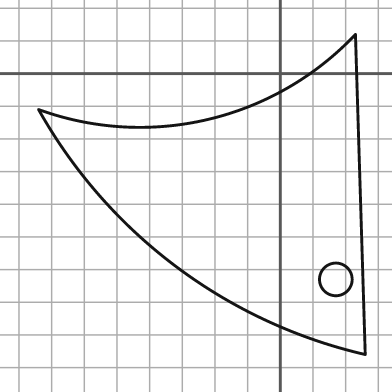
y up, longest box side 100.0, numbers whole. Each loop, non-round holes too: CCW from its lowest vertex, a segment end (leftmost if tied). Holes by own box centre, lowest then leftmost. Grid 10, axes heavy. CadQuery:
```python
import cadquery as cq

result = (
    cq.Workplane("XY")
    .moveTo(26.0, -86.0)
    .lineTo(23.0, 12.0)
    .threePointArc((-22.0, -14.0), (-74.0, -11.0))
    .threePointArc((-32.0, -59.0), (26.0, -86.0))
    .close()
    .moveTo(17.0, -63.0)
    .circle(5.0)
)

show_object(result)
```